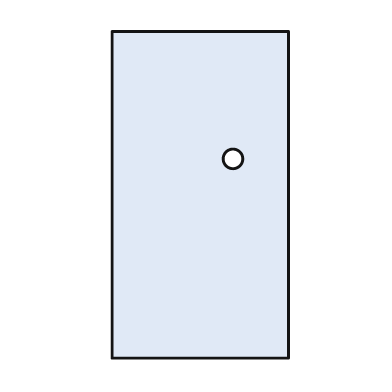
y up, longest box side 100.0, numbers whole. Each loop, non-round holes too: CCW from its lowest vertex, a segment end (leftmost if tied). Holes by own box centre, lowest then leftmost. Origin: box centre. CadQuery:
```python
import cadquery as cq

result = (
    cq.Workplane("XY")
    .moveTo(-27.0, -50.0)
    .lineTo(27.0, -50.0)
    .lineTo(27.0, 50.0)
    .lineTo(-27.0, 50.0)
    .close()
    .moveTo(10.0, 11.0)
    .circle(3.0)
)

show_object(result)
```